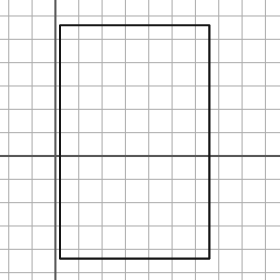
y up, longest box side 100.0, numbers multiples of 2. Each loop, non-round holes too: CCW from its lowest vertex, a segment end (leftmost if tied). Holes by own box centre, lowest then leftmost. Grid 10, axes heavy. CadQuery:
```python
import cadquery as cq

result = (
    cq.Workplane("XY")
    .moveTo(2.0, -44.0)
    .lineTo(66.0, -44.0)
    .lineTo(66.0, 56.0)
    .lineTo(2.0, 56.0)
    .close()
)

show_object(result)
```